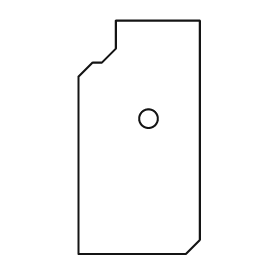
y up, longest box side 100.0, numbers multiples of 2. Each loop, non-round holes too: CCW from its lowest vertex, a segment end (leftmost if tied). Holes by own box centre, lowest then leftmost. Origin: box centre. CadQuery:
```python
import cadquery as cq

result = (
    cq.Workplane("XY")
    .moveTo(-26.0, -50.0)
    .lineTo(20.0, -50.0)
    .lineTo(26.0, -44.0)
    .lineTo(26.0, 50.0)
    .lineTo(-10.0, 50.0)
    .lineTo(-10.0, 38.0)
    .lineTo(-16.0, 32.0)
    .lineTo(-20.0, 32.0)
    .lineTo(-26.0, 26.0)
    .close()
    .moveTo(4.0, 8.0)
    .circle(4.0)
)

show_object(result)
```